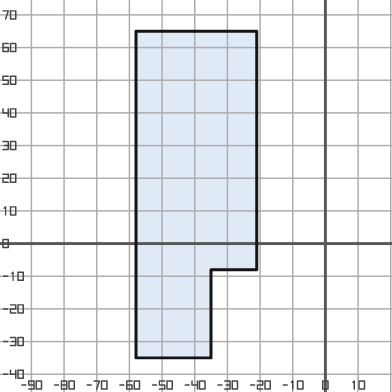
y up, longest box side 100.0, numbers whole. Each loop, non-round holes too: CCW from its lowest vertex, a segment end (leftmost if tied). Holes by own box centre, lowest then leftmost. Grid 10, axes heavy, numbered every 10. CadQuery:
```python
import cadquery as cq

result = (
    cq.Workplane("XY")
    .moveTo(-58.0, -35.0)
    .lineTo(-35.0, -35.0)
    .lineTo(-35.0, -8.0)
    .lineTo(-21.0, -8.0)
    .lineTo(-21.0, 65.0)
    .lineTo(-58.0, 65.0)
    .close()
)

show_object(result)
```